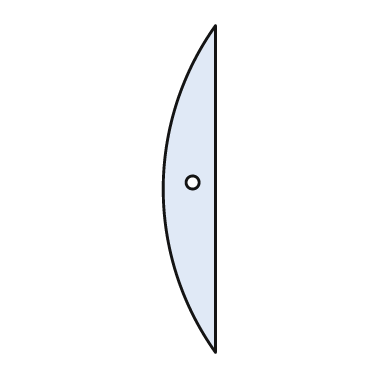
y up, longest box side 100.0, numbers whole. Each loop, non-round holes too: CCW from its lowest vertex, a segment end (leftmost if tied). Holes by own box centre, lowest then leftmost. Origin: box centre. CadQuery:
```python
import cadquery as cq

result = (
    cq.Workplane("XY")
    .moveTo(8.0, -50.0)
    .lineTo(8.0, 50.0)
    .threePointArc((-8.0, 0.0), (8.0, -50.0))
    .close()
    .moveTo(1.0, 2.0)
    .circle(2.0)
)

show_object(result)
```